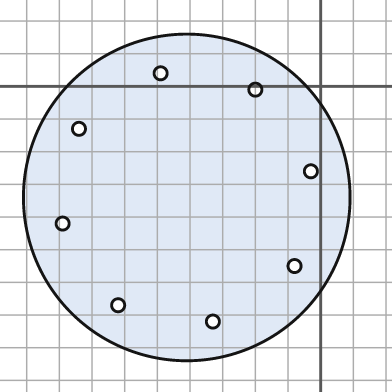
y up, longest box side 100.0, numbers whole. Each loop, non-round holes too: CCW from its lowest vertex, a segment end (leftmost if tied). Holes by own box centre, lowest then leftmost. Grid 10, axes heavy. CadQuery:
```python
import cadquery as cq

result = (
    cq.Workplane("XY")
    .moveTo(-41.0, -34.0)
    .circle(50.0)
    .moveTo(-33.0, -72.0)
    .circle(2.0)
    .moveTo(-62.0, -67.0)
    .circle(2.0)
    .moveTo(-8.0, -55.0)
    .circle(2.0)
    .moveTo(-79.0, -42.0)
    .circle(2.0)
    .moveTo(-3.0, -26.0)
    .circle(2.0)
    .moveTo(-74.0, -13.0)
    .circle(2.0)
    .moveTo(-20.0, -1.0)
    .circle(2.0)
    .moveTo(-49.0, 4.0)
    .circle(2.0)
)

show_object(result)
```